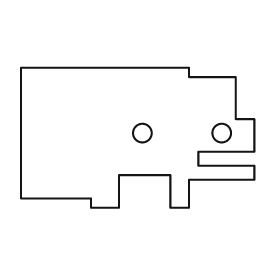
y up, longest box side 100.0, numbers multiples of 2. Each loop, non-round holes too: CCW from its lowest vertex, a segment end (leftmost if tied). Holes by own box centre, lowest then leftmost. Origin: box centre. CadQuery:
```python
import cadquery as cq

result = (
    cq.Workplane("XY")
    .moveTo(-20.0, -30.0)
    .lineTo(-8.0, -30.0)
    .lineTo(-8.0, -16.0)
    .lineTo(14.0, -16.0)
    .lineTo(14.0, -30.0)
    .lineTo(22.0, -30.0)
    .lineTo(22.0, -18.0)
    .lineTo(50.0, -18.0)
    .lineTo(50.0, -12.0)
    .lineTo(26.0, -12.0)
    .lineTo(26.0, -6.0)
    .lineTo(50.0, -6.0)
    .lineTo(50.0, 8.0)
    .lineTo(42.0, 8.0)
    .lineTo(42.0, 26.0)
    .lineTo(22.0, 26.0)
    .lineTo(22.0, 30.0)
    .lineTo(-50.0, 30.0)
    .lineTo(-50.0, -26.0)
    .lineTo(-20.0, -26.0)
    .close()
    .moveTo(2.0, 2.0)
    .circle(4.0)
    .moveTo(36.0, 2.0)
    .circle(4.0)
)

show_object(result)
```